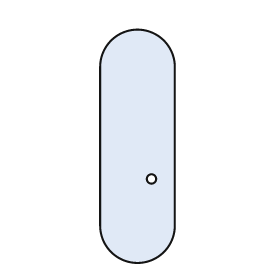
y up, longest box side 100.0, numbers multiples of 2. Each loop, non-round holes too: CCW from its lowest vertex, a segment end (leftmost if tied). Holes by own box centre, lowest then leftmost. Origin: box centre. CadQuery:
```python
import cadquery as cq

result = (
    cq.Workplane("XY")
    .moveTo(-16.0, -34.0)
    .threePointArc((0.0, -50.0), (16.0, -34.0))
    .lineTo(16.0, 34.0)
    .threePointArc((0.0, 50.0), (-16.0, 34.0))
    .close()
    .moveTo(6.0, -14.0)
    .circle(2.0)
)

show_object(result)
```